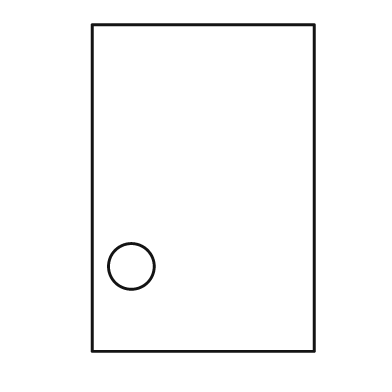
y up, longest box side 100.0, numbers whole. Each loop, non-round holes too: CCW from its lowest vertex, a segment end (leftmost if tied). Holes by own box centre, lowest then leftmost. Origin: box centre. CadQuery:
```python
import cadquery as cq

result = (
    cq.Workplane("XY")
    .moveTo(-34.0, -50.0)
    .lineTo(34.0, -50.0)
    .lineTo(34.0, 50.0)
    .lineTo(-34.0, 50.0)
    .close()
    .moveTo(-22.0, -24.0)
    .circle(7.0)
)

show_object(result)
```